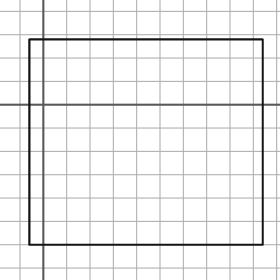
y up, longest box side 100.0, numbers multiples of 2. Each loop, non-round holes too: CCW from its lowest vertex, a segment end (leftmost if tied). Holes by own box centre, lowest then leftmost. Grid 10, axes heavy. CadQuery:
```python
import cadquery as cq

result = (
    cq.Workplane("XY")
    .moveTo(-6.0, -60.0)
    .lineTo(94.0, -60.0)
    .lineTo(94.0, 28.0)
    .lineTo(-6.0, 28.0)
    .close()
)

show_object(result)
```